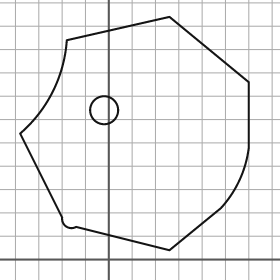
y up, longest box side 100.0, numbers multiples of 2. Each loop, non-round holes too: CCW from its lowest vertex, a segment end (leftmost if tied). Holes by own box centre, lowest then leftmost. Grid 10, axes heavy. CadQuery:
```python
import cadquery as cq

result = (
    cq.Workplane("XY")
    .moveTo(26.0, 4.0)
    .lineTo(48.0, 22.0)
    .threePointArc((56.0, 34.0), (60.0, 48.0))
    .lineTo(60.0, 76.0)
    .lineTo(26.0, 104.0)
    .lineTo(-18.0, 94.0)
    .threePointArc((-24.0, 72.0), (-38.0, 54.0))
    .lineTo(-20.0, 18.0)
    .threePointArc((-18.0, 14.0), (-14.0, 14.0))
    .close()
    .moveTo(-2.0, 64.0)
    .circle(6.0)
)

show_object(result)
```